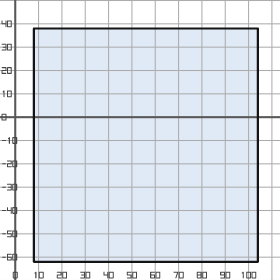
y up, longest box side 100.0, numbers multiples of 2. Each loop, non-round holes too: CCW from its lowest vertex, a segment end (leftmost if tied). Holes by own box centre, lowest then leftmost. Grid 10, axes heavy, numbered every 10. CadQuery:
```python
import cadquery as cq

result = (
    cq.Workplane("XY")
    .moveTo(8.0, -62.0)
    .lineTo(104.0, -62.0)
    .lineTo(104.0, 38.0)
    .lineTo(8.0, 38.0)
    .close()
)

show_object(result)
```